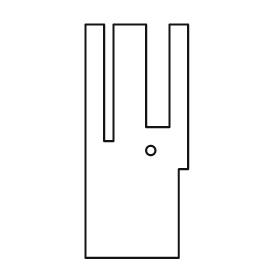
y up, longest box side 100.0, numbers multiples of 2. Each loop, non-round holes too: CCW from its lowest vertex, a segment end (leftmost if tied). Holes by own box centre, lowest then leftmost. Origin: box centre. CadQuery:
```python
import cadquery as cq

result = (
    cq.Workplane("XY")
    .moveTo(-22.0, -50.0)
    .lineTo(18.0, -50.0)
    .lineTo(18.0, -12.0)
    .lineTo(22.0, -12.0)
    .lineTo(22.0, 50.0)
    .lineTo(14.0, 50.0)
    .lineTo(14.0, 6.0)
    .lineTo(4.0, 6.0)
    .lineTo(4.0, 50.0)
    .lineTo(-10.0, 50.0)
    .lineTo(-10.0, 0.0)
    .lineTo(-14.0, 0.0)
    .lineTo(-14.0, 50.0)
    .lineTo(-22.0, 50.0)
    .close()
    .moveTo(6.0, -4.0)
    .circle(2.0)
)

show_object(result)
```